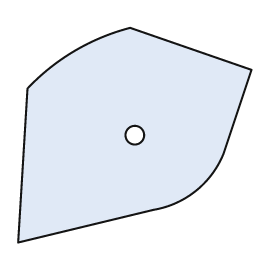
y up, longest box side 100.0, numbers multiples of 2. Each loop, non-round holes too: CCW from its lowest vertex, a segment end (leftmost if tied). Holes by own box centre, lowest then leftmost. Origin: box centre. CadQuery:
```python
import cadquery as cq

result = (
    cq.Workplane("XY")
    .moveTo(-50.0, -46.0)
    .lineTo(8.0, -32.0)
    .threePointArc((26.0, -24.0), (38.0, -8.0))
    .lineTo(50.0, 28.0)
    .lineTo(-2.0, 46.0)
    .threePointArc((-26.0, 36.0), (-46.0, 20.0))
    .close()
    .moveTo(0.0, 0.0)
    .circle(4.0)
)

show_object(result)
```